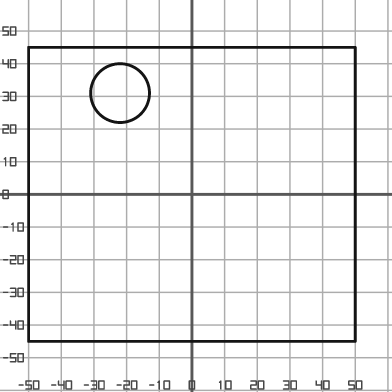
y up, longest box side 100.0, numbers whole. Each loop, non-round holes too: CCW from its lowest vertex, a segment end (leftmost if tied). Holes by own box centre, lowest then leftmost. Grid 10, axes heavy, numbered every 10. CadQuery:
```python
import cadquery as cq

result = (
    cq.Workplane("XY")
    .moveTo(-50.0, -45.0)
    .lineTo(50.0, -45.0)
    .lineTo(50.0, 45.0)
    .lineTo(-50.0, 45.0)
    .close()
    .moveTo(-22.0, 31.0)
    .circle(9.0)
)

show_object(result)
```